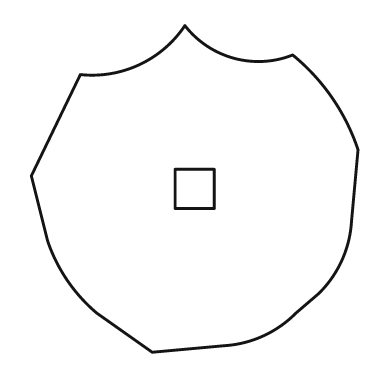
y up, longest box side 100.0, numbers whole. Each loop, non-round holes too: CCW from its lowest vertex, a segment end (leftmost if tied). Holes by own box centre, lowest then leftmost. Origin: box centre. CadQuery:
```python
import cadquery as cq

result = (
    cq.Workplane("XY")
    .moveTo(-13.0, -50.0)
    .lineTo(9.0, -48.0)
    .threePointArc((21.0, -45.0), (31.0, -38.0))
    .lineTo(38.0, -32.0)
    .threePointArc((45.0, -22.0), (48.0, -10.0))
    .lineTo(50.0, 12.0)
    .threePointArc((42.0, 28.0), (30.0, 41.0))
    .threePointArc((12.0, 40.0), (-3.0, 50.0))
    .threePointArc((-17.0, 38.0), (-35.0, 35.0))
    .lineTo(-50.0, 4.0)
    .lineTo(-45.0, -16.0)
    .threePointArc((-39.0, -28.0), (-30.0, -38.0))
    .close()
    .moveTo(-6.0, -6.0)
    .lineTo(6.0, -6.0)
    .lineTo(6.0, 6.0)
    .lineTo(-6.0, 6.0)
    .close()
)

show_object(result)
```